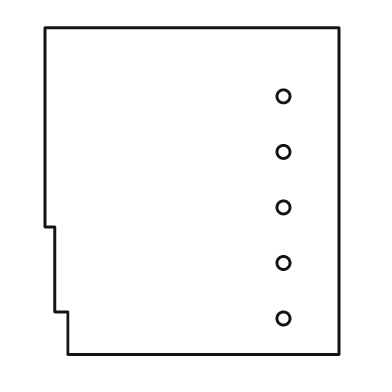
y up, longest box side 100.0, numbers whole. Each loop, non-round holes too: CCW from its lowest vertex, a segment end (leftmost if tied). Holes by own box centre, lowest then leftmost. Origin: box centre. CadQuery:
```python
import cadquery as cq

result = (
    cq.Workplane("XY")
    .moveTo(-38.0, -50.0)
    .lineTo(45.0, -50.0)
    .lineTo(45.0, 50.0)
    .lineTo(-45.0, 50.0)
    .lineTo(-45.0, -11.0)
    .lineTo(-42.0, -11.0)
    .lineTo(-42.0, -37.0)
    .lineTo(-38.0, -37.0)
    .close()
    .moveTo(28.0, -39.0)
    .circle(2.0)
    .moveTo(28.0, -22.0)
    .circle(2.0)
    .moveTo(28.0, -5.0)
    .circle(2.0)
    .moveTo(28.0, 12.0)
    .circle(2.0)
    .moveTo(28.0, 29.0)
    .circle(2.0)
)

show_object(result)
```